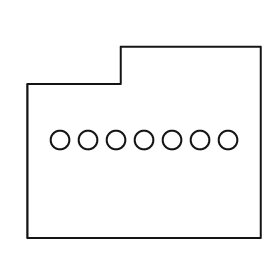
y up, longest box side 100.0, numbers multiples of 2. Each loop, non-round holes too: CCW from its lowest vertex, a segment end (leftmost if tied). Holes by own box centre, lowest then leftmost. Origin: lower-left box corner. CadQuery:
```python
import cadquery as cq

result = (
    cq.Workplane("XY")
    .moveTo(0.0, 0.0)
    .lineTo(100.0, 0.0)
    .lineTo(100.0, 82.0)
    .lineTo(40.0, 82.0)
    .lineTo(40.0, 66.0)
    .lineTo(0.0, 66.0)
    .close()
    .moveTo(14.0, 42.0)
    .circle(4.0)
    .moveTo(26.0, 42.0)
    .circle(4.0)
    .moveTo(38.0, 42.0)
    .circle(4.0)
    .moveTo(50.0, 42.0)
    .circle(4.0)
    .moveTo(62.0, 42.0)
    .circle(4.0)
    .moveTo(74.0, 42.0)
    .circle(4.0)
    .moveTo(86.0, 42.0)
    .circle(4.0)
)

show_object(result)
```